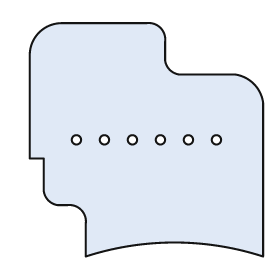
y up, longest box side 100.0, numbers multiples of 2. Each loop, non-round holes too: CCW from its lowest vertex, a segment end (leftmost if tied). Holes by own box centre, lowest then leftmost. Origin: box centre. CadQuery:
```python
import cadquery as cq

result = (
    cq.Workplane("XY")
    .moveTo(-26.0, -50.0)
    .threePointArc((12.0, -44.0), (50.0, -50.0))
    .lineTo(50.0, 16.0)
    .threePointArc((46.0, 24.0), (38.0, 28.0))
    .lineTo(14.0, 28.0)
    .threePointArc((10.0, 30.0), (8.0, 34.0))
    .lineTo(8.0, 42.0)
    .threePointArc((6.0, 48.0), (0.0, 50.0))
    .lineTo(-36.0, 50.0)
    .threePointArc((-46.0, 46.0), (-50.0, 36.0))
    .lineTo(-50.0, -8.0)
    .lineTo(-44.0, -8.0)
    .lineTo(-44.0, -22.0)
    .threePointArc((-42.0, -26.0), (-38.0, -28.0))
    .lineTo(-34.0, -28.0)
    .threePointArc((-28.0, -30.0), (-26.0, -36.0))
    .close()
    .moveTo(-30.0, 0.0)
    .circle(2.0)
    .moveTo(-18.0, 0.0)
    .circle(2.0)
    .moveTo(-6.0, 0.0)
    .circle(2.0)
    .moveTo(6.0, 0.0)
    .circle(2.0)
    .moveTo(18.0, 0.0)
    .circle(2.0)
    .moveTo(30.0, 0.0)
    .circle(2.0)
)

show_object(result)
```